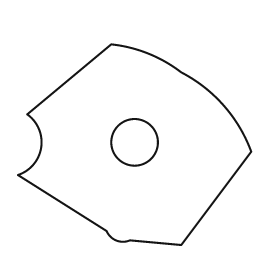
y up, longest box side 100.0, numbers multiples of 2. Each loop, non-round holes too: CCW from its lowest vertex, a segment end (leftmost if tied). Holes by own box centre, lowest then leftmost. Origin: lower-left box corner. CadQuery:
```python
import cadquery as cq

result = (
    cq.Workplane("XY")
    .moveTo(70.0, 0.0)
    .lineTo(100.0, 40.0)
    .threePointArc((88.0, 60.0), (70.0, 74.0))
    .threePointArc((56.0, 82.0), (40.0, 86.0))
    .lineTo(4.0, 56.0)
    .threePointArc((10.0, 42.0), (0.0, 30.0))
    .lineTo(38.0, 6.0)
    .threePointArc((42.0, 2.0), (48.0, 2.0))
    .close()
    .moveTo(50.0, 44.0)
    .circle(10.0)
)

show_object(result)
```